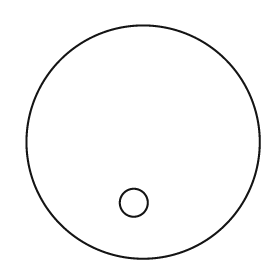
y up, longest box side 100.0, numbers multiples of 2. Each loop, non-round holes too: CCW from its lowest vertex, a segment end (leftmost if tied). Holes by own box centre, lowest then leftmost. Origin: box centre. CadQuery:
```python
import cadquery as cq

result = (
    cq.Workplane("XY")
    .moveTo(0.0, 0.0)
    .circle(50.0)
    .moveTo(-4.0, -26.0)
    .circle(6.0)
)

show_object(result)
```